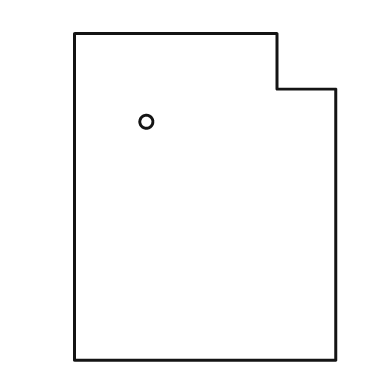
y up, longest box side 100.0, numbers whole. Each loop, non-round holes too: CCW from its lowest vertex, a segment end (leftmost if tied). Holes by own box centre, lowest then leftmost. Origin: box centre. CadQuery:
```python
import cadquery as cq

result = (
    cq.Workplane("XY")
    .moveTo(-40.0, -50.0)
    .lineTo(40.0, -50.0)
    .lineTo(40.0, 33.0)
    .lineTo(22.0, 33.0)
    .lineTo(22.0, 50.0)
    .lineTo(-40.0, 50.0)
    .close()
    .moveTo(-18.0, 23.0)
    .circle(2.0)
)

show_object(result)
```